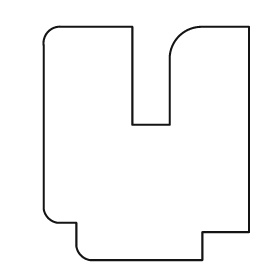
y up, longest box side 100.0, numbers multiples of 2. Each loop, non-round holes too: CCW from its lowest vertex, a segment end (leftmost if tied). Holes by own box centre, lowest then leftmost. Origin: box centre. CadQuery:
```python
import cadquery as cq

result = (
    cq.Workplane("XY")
    .moveTo(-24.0, -50.0)
    .lineTo(24.0, -50.0)
    .lineTo(24.0, -38.0)
    .lineTo(44.0, -38.0)
    .lineTo(44.0, 50.0)
    .lineTo(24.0, 50.0)
    .threePointArc((14.0, 46.0), (10.0, 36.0))
    .lineTo(10.0, 8.0)
    .lineTo(-6.0, 8.0)
    .lineTo(-6.0, 50.0)
    .lineTo(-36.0, 50.0)
    .threePointArc((-42.0, 48.0), (-44.0, 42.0))
    .lineTo(-44.0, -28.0)
    .threePointArc((-42.0, -32.0), (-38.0, -34.0))
    .lineTo(-30.0, -34.0)
    .lineTo(-30.0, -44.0)
    .threePointArc((-28.0, -48.0), (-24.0, -50.0))
    .close()
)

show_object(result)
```